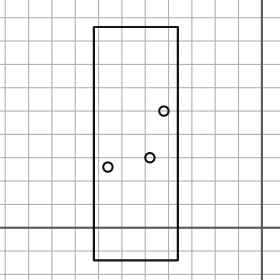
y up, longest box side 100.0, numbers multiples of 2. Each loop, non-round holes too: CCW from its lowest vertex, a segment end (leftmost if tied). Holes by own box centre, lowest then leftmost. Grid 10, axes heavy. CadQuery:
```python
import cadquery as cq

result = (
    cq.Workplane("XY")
    .moveTo(-72.0, -14.0)
    .lineTo(-36.0, -14.0)
    .lineTo(-36.0, 86.0)
    .lineTo(-72.0, 86.0)
    .close()
    .moveTo(-66.0, 26.0)
    .circle(2.0)
    .moveTo(-48.0, 30.0)
    .circle(2.0)
    .moveTo(-42.0, 50.0)
    .circle(2.0)
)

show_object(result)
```